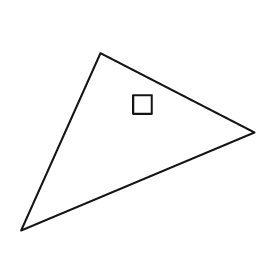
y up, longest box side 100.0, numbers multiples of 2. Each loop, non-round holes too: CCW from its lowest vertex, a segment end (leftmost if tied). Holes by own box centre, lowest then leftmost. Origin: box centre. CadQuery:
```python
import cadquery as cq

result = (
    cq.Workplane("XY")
    .moveTo(-50.0, -38.0)
    .lineTo(50.0, 4.0)
    .lineTo(-16.0, 38.0)
    .close()
    .moveTo(-2.0, 12.0)
    .lineTo(6.0, 12.0)
    .lineTo(6.0, 20.0)
    .lineTo(-2.0, 20.0)
    .close()
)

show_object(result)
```